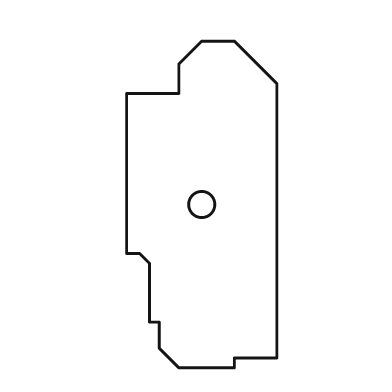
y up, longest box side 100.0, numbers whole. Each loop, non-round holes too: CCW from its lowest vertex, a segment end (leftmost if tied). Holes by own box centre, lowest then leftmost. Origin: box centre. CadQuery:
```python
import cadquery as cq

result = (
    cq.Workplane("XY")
    .moveTo(-7.0, -50.0)
    .lineTo(10.0, -50.0)
    .lineTo(10.0, -47.0)
    .lineTo(23.0, -47.0)
    .lineTo(23.0, 37.0)
    .lineTo(10.0, 50.0)
    .lineTo(0.0, 50.0)
    .lineTo(-7.0, 43.0)
    .lineTo(-7.0, 34.0)
    .lineTo(-23.0, 34.0)
    .lineTo(-23.0, -15.0)
    .lineTo(-19.0, -15.0)
    .lineTo(-16.0, -18.0)
    .lineTo(-16.0, -36.0)
    .lineTo(-13.0, -36.0)
    .lineTo(-13.0, -44.0)
    .close()
    .moveTo(0.0, 0.0)
    .circle(4.0)
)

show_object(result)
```